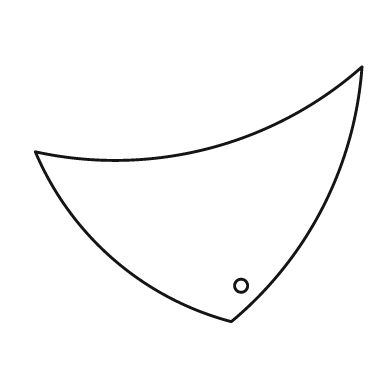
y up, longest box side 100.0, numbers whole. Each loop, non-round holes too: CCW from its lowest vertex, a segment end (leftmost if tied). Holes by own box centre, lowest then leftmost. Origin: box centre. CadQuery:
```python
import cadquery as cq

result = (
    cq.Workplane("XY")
    .moveTo(10.0, -39.0)
    .threePointArc((38.0, -4.0), (50.0, 39.0))
    .threePointArc((3.0, 14.0), (-50.0, 13.0))
    .threePointArc((-26.0, -20.0), (10.0, -39.0))
    .close()
    .moveTo(13.0, -28.0)
    .circle(2.0)
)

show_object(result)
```